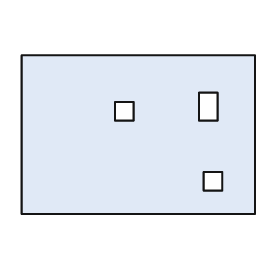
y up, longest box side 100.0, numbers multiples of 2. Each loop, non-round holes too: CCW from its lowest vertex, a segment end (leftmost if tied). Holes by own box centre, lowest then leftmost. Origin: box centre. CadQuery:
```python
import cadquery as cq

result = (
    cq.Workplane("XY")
    .moveTo(-50.0, -34.0)
    .lineTo(50.0, -34.0)
    .lineTo(50.0, 34.0)
    .lineTo(-50.0, 34.0)
    .close()
    .moveTo(28.0, -24.0)
    .lineTo(36.0, -24.0)
    .lineTo(36.0, -16.0)
    .lineTo(28.0, -16.0)
    .close()
    .moveTo(-10.0, 6.0)
    .lineTo(-2.0, 6.0)
    .lineTo(-2.0, 14.0)
    .lineTo(-10.0, 14.0)
    .close()
    .moveTo(26.0, 6.0)
    .lineTo(34.0, 6.0)
    .lineTo(34.0, 18.0)
    .lineTo(26.0, 18.0)
    .close()
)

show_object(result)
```